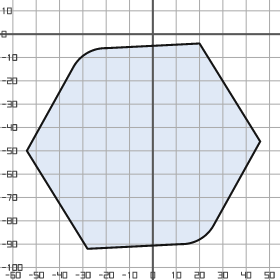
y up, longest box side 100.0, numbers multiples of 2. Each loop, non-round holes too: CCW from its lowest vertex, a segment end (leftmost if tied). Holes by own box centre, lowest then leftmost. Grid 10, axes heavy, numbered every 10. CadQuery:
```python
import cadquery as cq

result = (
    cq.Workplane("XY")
    .moveTo(-28.0, -92.0)
    .lineTo(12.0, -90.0)
    .threePointArc((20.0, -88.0), (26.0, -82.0))
    .lineTo(46.0, -46.0)
    .lineTo(20.0, -4.0)
    .lineTo(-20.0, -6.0)
    .threePointArc((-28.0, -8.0), (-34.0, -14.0))
    .lineTo(-54.0, -50.0)
    .close()
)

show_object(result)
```